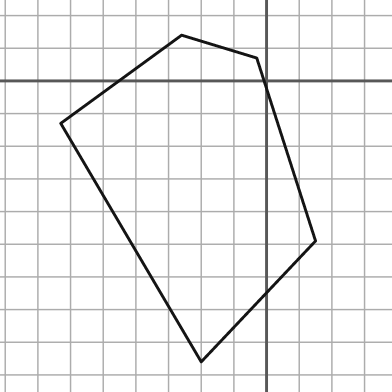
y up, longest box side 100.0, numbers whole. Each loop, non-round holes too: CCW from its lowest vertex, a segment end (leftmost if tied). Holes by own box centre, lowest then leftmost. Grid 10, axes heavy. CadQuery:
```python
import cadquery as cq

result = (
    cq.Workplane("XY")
    .moveTo(-20.0, -86.0)
    .lineTo(15.0, -49.0)
    .lineTo(-3.0, 7.0)
    .lineTo(-26.0, 14.0)
    .lineTo(-63.0, -13.0)
    .close()
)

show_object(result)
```